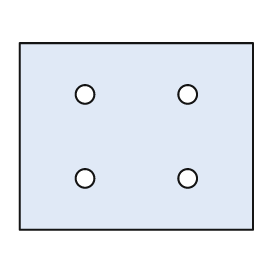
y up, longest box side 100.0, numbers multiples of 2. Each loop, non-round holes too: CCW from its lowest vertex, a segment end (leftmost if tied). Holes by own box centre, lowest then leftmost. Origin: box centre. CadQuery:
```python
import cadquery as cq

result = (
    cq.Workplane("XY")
    .moveTo(-50.0, -40.0)
    .lineTo(50.0, -40.0)
    .lineTo(50.0, 40.0)
    .lineTo(-50.0, 40.0)
    .close()
    .moveTo(-22.0, -18.0)
    .circle(4.0)
    .moveTo(22.0, -18.0)
    .circle(4.0)
    .moveTo(-22.0, 18.0)
    .circle(4.0)
    .moveTo(22.0, 18.0)
    .circle(4.0)
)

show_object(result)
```